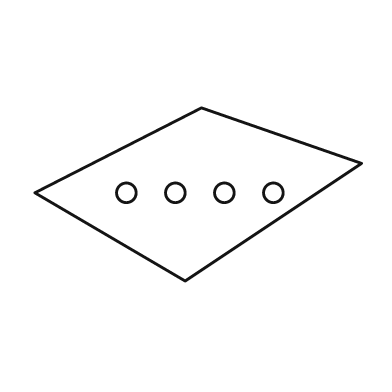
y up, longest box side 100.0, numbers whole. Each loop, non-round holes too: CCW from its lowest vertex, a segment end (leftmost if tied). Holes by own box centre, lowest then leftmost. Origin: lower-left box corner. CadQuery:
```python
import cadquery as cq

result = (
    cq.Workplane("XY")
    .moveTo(46.0, 0.0)
    .lineTo(100.0, 36.0)
    .lineTo(51.0, 53.0)
    .lineTo(0.0, 27.0)
    .close()
    .moveTo(28.0, 27.0)
    .circle(3.0)
    .moveTo(43.0, 27.0)
    .circle(3.0)
    .moveTo(58.0, 27.0)
    .circle(3.0)
    .moveTo(73.0, 27.0)
    .circle(3.0)
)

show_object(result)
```